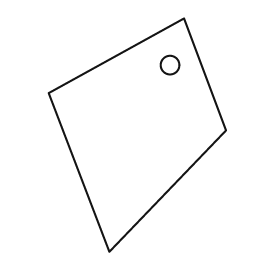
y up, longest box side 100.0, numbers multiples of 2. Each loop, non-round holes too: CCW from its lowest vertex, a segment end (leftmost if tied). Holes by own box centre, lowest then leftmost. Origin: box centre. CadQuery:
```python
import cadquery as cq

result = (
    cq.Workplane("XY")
    .moveTo(-12.0, -50.0)
    .lineTo(38.0, 2.0)
    .lineTo(20.0, 50.0)
    .lineTo(-38.0, 18.0)
    .close()
    .moveTo(14.0, 30.0)
    .circle(4.0)
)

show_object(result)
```